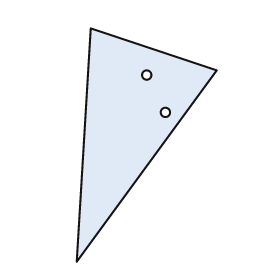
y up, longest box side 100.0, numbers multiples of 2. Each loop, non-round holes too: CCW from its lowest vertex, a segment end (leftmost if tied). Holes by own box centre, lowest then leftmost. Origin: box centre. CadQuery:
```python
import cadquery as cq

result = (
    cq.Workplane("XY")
    .moveTo(-30.0, -50.0)
    .lineTo(30.0, 32.0)
    .lineTo(-24.0, 50.0)
    .close()
    .moveTo(8.0, 14.0)
    .circle(2.0)
    .moveTo(0.0, 30.0)
    .circle(2.0)
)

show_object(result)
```